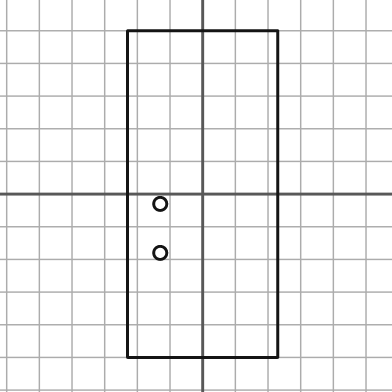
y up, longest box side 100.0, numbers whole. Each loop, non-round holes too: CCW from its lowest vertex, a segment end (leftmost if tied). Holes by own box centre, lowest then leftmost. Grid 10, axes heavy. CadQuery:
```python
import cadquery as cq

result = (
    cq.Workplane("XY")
    .moveTo(-23.0, -50.0)
    .lineTo(23.0, -50.0)
    .lineTo(23.0, 50.0)
    .lineTo(-23.0, 50.0)
    .close()
    .moveTo(-13.0, -18.0)
    .circle(2.0)
    .moveTo(-13.0, -3.0)
    .circle(2.0)
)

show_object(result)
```